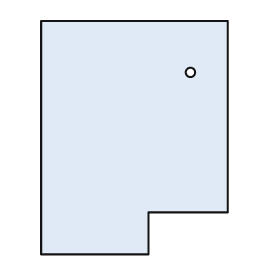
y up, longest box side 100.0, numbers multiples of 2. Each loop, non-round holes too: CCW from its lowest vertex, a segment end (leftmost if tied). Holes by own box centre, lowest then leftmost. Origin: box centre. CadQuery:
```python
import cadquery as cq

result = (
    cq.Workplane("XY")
    .moveTo(-40.0, -50.0)
    .lineTo(6.0, -50.0)
    .lineTo(6.0, -32.0)
    .lineTo(40.0, -32.0)
    .lineTo(40.0, 50.0)
    .lineTo(-40.0, 50.0)
    .close()
    .moveTo(24.0, 28.0)
    .circle(2.0)
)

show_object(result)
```